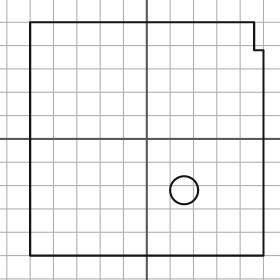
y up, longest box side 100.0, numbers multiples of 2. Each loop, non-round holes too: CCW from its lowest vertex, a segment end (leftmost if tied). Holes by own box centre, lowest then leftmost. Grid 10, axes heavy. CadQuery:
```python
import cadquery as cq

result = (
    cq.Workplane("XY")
    .moveTo(-50.0, -50.0)
    .lineTo(50.0, -50.0)
    .lineTo(50.0, 38.0)
    .lineTo(46.0, 38.0)
    .lineTo(46.0, 50.0)
    .lineTo(-50.0, 50.0)
    .close()
    .moveTo(16.0, -22.0)
    .circle(6.0)
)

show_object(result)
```